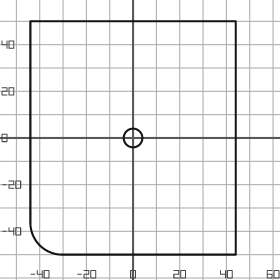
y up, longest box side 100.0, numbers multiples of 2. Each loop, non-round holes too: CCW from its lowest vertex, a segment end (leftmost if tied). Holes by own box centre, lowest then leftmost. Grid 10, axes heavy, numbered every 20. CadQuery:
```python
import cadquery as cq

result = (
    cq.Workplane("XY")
    .moveTo(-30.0, -50.0)
    .lineTo(44.0, -50.0)
    .lineTo(44.0, 50.0)
    .lineTo(-44.0, 50.0)
    .lineTo(-44.0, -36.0)
    .threePointArc((-40.0, -46.0), (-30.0, -50.0))
    .close()
    .moveTo(0.0, 0.0)
    .circle(4.0)
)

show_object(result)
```